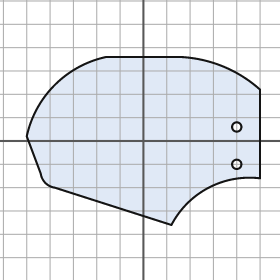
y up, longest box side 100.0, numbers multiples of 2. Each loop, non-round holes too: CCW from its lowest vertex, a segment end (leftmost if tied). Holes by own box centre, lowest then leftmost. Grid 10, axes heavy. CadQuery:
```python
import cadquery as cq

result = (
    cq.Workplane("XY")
    .moveTo(12.0, -36.0)
    .threePointArc((28.0, -20.0), (50.0, -16.0))
    .lineTo(50.0, 22.0)
    .threePointArc((34.0, 32.0), (16.0, 36.0))
    .lineTo(-16.0, 36.0)
    .threePointArc((-38.0, 24.0), (-50.0, 2.0))
    .lineTo(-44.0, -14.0)
    .threePointArc((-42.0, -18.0), (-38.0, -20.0))
    .close()
    .moveTo(40.0, -10.0)
    .circle(2.0)
    .moveTo(40.0, 6.0)
    .circle(2.0)
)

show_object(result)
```